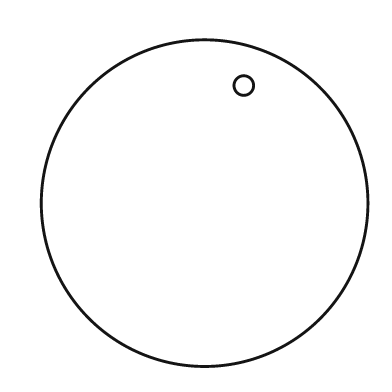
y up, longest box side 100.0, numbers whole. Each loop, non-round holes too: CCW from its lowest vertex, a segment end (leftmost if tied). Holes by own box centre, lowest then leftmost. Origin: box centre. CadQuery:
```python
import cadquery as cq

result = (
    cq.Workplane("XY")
    .moveTo(0.0, 0.0)
    .circle(50.0)
    .moveTo(12.0, 36.0)
    .circle(3.0)
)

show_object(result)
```